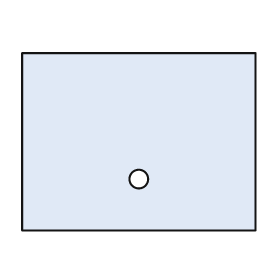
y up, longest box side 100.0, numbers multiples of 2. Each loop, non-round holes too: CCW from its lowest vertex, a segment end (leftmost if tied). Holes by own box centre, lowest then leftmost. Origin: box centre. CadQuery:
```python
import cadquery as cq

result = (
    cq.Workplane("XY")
    .moveTo(-50.0, -38.0)
    .lineTo(50.0, -38.0)
    .lineTo(50.0, 38.0)
    .lineTo(-50.0, 38.0)
    .close()
    .moveTo(0.0, -16.0)
    .circle(4.0)
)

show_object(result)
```